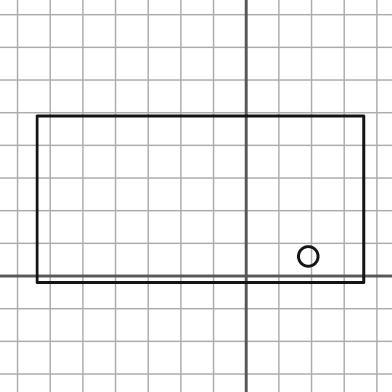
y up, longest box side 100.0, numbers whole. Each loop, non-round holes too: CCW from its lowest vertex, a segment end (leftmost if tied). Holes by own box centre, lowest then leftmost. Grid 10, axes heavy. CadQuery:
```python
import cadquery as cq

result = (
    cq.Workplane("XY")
    .moveTo(-64.0, -2.0)
    .lineTo(36.0, -2.0)
    .lineTo(36.0, 49.0)
    .lineTo(-64.0, 49.0)
    .close()
    .moveTo(19.0, 6.0)
    .circle(3.0)
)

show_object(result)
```